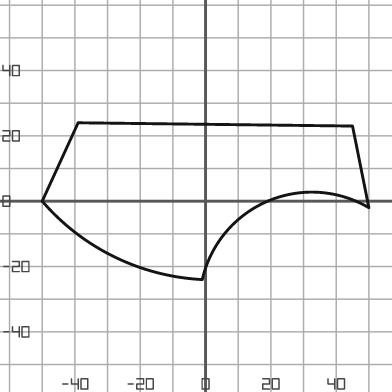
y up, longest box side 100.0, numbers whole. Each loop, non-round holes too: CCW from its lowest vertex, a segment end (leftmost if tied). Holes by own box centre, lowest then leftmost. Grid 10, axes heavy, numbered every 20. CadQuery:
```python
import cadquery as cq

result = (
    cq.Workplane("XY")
    .moveTo(-1.0, -24.0)
    .threePointArc((19.0, 0.0), (50.0, -2.0))
    .lineTo(45.0, 23.0)
    .lineTo(-39.0, 24.0)
    .lineTo(-50.0, 0.0)
    .threePointArc((-28.0, -17.0), (-1.0, -24.0))
    .close()
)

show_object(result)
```